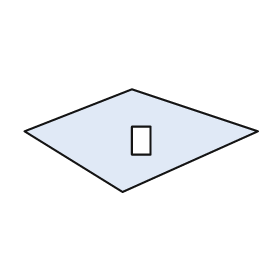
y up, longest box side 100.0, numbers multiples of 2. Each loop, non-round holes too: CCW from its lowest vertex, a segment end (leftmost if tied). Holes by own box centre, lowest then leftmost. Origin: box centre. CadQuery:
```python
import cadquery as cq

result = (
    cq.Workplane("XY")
    .moveTo(-8.0, -22.0)
    .lineTo(50.0, 4.0)
    .lineTo(-4.0, 22.0)
    .lineTo(-50.0, 4.0)
    .close()
    .moveTo(-4.0, -6.0)
    .lineTo(4.0, -6.0)
    .lineTo(4.0, 6.0)
    .lineTo(-4.0, 6.0)
    .close()
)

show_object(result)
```